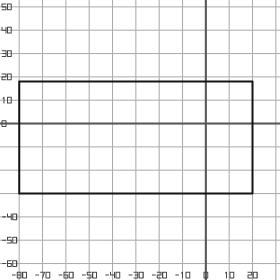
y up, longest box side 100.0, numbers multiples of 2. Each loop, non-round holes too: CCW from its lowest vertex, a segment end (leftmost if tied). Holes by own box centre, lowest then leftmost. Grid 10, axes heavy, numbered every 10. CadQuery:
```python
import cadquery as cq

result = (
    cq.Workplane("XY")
    .moveTo(-80.0, -30.0)
    .lineTo(20.0, -30.0)
    .lineTo(20.0, 18.0)
    .lineTo(-80.0, 18.0)
    .close()
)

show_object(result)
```